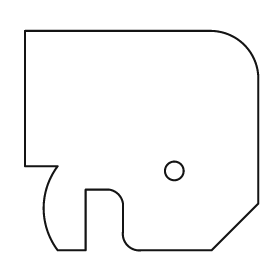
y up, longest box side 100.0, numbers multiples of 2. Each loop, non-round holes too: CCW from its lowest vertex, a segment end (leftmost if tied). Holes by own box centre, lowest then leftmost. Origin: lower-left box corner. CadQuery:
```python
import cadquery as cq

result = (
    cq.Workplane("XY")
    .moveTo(14.0, 0.0)
    .lineTo(26.0, 0.0)
    .lineTo(26.0, 26.0)
    .lineTo(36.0, 26.0)
    .threePointArc((40.0, 24.0), (42.0, 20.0))
    .lineTo(42.0, 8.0)
    .threePointArc((44.0, 2.0), (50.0, 0.0))
    .lineTo(80.0, 0.0)
    .lineTo(100.0, 20.0)
    .lineTo(100.0, 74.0)
    .threePointArc((94.0, 88.0), (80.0, 94.0))
    .lineTo(0.0, 94.0)
    .lineTo(0.0, 36.0)
    .lineTo(14.0, 36.0)
    .threePointArc((8.0, 18.0), (14.0, 0.0))
    .close()
    .moveTo(64.0, 34.0)
    .circle(4.0)
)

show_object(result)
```